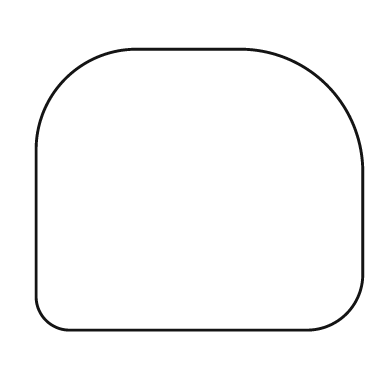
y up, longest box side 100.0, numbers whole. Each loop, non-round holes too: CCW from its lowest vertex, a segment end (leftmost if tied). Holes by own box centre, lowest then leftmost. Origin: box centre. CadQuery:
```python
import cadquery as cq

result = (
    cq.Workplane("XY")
    .moveTo(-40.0, -43.0)
    .lineTo(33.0, -43.0)
    .threePointArc((45.0, -38.0), (50.0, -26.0))
    .lineTo(50.0, 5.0)
    .threePointArc((39.0, 32.0), (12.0, 43.0))
    .lineTo(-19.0, 43.0)
    .threePointArc((-41.0, 34.0), (-50.0, 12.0))
    .lineTo(-50.0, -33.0)
    .threePointArc((-47.0, -40.0), (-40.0, -43.0))
    .close()
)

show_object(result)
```